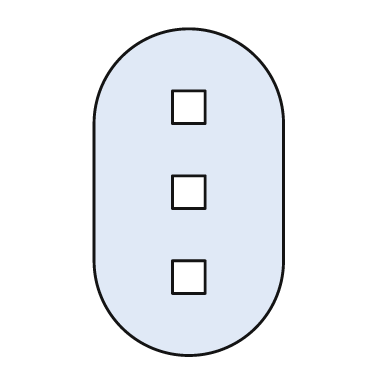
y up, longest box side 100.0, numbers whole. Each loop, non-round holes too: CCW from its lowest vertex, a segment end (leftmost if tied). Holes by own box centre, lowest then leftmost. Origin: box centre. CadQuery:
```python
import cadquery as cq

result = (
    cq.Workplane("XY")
    .moveTo(-29.0, -21.0)
    .threePointArc((0.0, -50.0), (29.0, -21.0))
    .lineTo(29.0, 21.0)
    .threePointArc((0.0, 50.0), (-29.0, 21.0))
    .close()
    .moveTo(-5.0, -31.0)
    .lineTo(5.0, -31.0)
    .lineTo(5.0, -21.0)
    .lineTo(-5.0, -21.0)
    .close()
    .moveTo(-5.0, -5.0)
    .lineTo(5.0, -5.0)
    .lineTo(5.0, 5.0)
    .lineTo(-5.0, 5.0)
    .close()
    .moveTo(-5.0, 21.0)
    .lineTo(5.0, 21.0)
    .lineTo(5.0, 31.0)
    .lineTo(-5.0, 31.0)
    .close()
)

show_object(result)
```